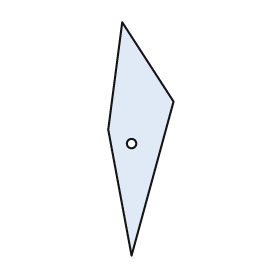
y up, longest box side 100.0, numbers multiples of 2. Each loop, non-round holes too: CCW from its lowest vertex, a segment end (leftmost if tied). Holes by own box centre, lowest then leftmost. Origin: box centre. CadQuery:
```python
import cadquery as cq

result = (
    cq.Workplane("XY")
    .moveTo(-4.0, -50.0)
    .lineTo(14.0, 16.0)
    .lineTo(-8.0, 50.0)
    .lineTo(-14.0, 4.0)
    .close()
    .moveTo(-4.0, -2.0)
    .circle(2.0)
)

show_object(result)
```